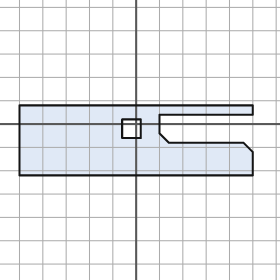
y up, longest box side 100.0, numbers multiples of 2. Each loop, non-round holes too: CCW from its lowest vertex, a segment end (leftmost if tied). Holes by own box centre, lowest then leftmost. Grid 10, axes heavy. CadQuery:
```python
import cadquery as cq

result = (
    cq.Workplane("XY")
    .moveTo(-50.0, -22.0)
    .lineTo(50.0, -22.0)
    .lineTo(50.0, -12.0)
    .lineTo(46.0, -8.0)
    .lineTo(14.0, -8.0)
    .lineTo(10.0, -4.0)
    .lineTo(10.0, 4.0)
    .lineTo(50.0, 4.0)
    .lineTo(50.0, 8.0)
    .lineTo(-50.0, 8.0)
    .close()
    .moveTo(-6.0, -6.0)
    .lineTo(2.0, -6.0)
    .lineTo(2.0, 2.0)
    .lineTo(-6.0, 2.0)
    .close()
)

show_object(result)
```